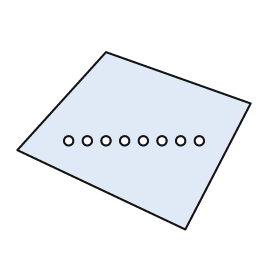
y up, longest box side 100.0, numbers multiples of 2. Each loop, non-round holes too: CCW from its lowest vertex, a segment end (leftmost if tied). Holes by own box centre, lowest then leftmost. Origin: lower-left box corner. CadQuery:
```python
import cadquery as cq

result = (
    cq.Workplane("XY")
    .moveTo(72.0, 0.0)
    .lineTo(100.0, 54.0)
    .lineTo(38.0, 76.0)
    .lineTo(0.0, 34.0)
    .close()
    .moveTo(22.0, 38.0)
    .circle(2.0)
    .moveTo(30.0, 38.0)
    .circle(2.0)
    .moveTo(38.0, 38.0)
    .circle(2.0)
    .moveTo(46.0, 38.0)
    .circle(2.0)
    .moveTo(54.0, 38.0)
    .circle(2.0)
    .moveTo(62.0, 38.0)
    .circle(2.0)
    .moveTo(70.0, 38.0)
    .circle(2.0)
    .moveTo(78.0, 38.0)
    .circle(2.0)
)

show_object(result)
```